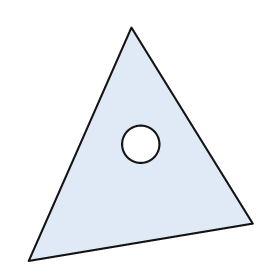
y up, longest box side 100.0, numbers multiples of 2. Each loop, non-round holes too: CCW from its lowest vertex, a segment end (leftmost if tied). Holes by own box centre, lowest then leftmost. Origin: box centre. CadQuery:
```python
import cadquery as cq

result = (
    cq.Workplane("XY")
    .moveTo(-48.0, -50.0)
    .lineTo(48.0, -34.0)
    .lineTo(-4.0, 50.0)
    .close()
    .moveTo(0.0, 0.0)
    .circle(8.0)
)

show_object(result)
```